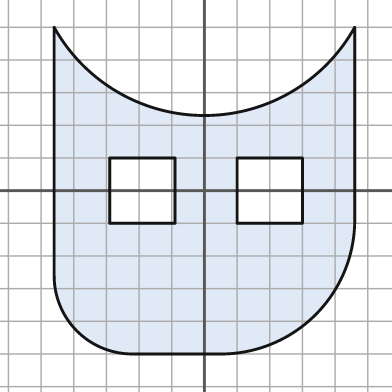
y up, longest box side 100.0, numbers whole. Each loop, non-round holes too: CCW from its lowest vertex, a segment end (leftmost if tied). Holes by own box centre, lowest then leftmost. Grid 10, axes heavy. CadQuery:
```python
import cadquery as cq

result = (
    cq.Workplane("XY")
    .moveTo(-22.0, -50.0)
    .lineTo(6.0, -50.0)
    .threePointArc((34.0, -38.0), (46.0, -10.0))
    .lineTo(46.0, 50.0)
    .threePointArc((0.0, 23.0), (-46.0, 50.0))
    .lineTo(-46.0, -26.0)
    .threePointArc((-39.0, -43.0), (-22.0, -50.0))
    .close()
    .moveTo(-29.0, -10.0)
    .lineTo(-9.0, -10.0)
    .lineTo(-9.0, 10.0)
    .lineTo(-29.0, 10.0)
    .close()
    .moveTo(10.0, -10.0)
    .lineTo(30.0, -10.0)
    .lineTo(30.0, 10.0)
    .lineTo(10.0, 10.0)
    .close()
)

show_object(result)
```